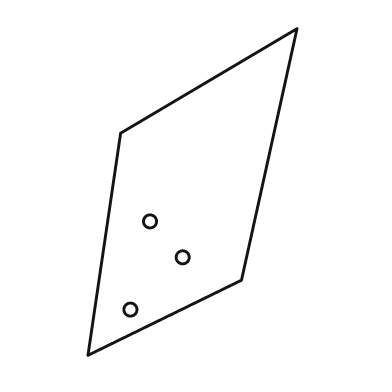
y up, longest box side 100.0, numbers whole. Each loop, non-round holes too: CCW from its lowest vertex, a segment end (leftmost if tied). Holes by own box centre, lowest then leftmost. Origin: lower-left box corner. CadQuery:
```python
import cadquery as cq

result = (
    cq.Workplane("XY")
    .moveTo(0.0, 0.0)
    .lineTo(47.0, 23.0)
    .lineTo(64.0, 100.0)
    .lineTo(10.0, 68.0)
    .close()
    .moveTo(13.0, 14.0)
    .circle(2.0)
    .moveTo(29.0, 30.0)
    .circle(2.0)
    .moveTo(19.0, 41.0)
    .circle(2.0)
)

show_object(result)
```